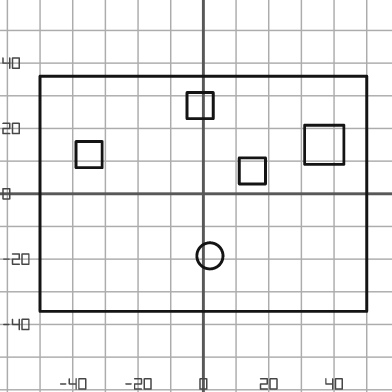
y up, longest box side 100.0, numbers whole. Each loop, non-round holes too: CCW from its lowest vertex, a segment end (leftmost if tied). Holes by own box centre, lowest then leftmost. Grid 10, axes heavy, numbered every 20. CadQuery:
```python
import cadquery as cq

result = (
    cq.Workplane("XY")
    .moveTo(-50.0, -36.0)
    .lineTo(50.0, -36.0)
    .lineTo(50.0, 36.0)
    .lineTo(-50.0, 36.0)
    .close()
    .moveTo(2.0, -19.0)
    .circle(4.0)
    .moveTo(11.0, 3.0)
    .lineTo(19.0, 3.0)
    .lineTo(19.0, 11.0)
    .lineTo(11.0, 11.0)
    .close()
    .moveTo(-39.0, 8.0)
    .lineTo(-31.0, 8.0)
    .lineTo(-31.0, 16.0)
    .lineTo(-39.0, 16.0)
    .close()
    .moveTo(31.0, 9.0)
    .lineTo(43.0, 9.0)
    .lineTo(43.0, 21.0)
    .lineTo(31.0, 21.0)
    .close()
    .moveTo(-5.0, 23.0)
    .lineTo(3.0, 23.0)
    .lineTo(3.0, 31.0)
    .lineTo(-5.0, 31.0)
    .close()
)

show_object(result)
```